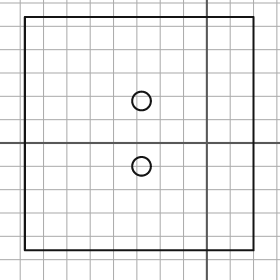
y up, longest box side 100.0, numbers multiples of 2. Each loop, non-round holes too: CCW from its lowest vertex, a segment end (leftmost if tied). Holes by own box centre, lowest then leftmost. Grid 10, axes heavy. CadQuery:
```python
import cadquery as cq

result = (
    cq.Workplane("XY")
    .moveTo(-78.0, -46.0)
    .lineTo(20.0, -46.0)
    .lineTo(20.0, 54.0)
    .lineTo(-78.0, 54.0)
    .close()
    .moveTo(-28.0, -10.0)
    .circle(4.0)
    .moveTo(-28.0, 18.0)
    .circle(4.0)
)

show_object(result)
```